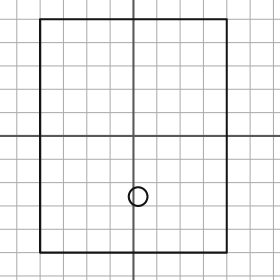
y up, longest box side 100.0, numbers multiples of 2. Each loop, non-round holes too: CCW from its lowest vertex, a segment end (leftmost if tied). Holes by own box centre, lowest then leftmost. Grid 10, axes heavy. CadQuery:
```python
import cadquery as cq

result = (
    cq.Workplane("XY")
    .moveTo(-40.0, -50.0)
    .lineTo(40.0, -50.0)
    .lineTo(40.0, 50.0)
    .lineTo(-40.0, 50.0)
    .close()
    .moveTo(2.0, -26.0)
    .circle(4.0)
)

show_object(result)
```